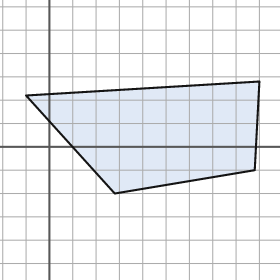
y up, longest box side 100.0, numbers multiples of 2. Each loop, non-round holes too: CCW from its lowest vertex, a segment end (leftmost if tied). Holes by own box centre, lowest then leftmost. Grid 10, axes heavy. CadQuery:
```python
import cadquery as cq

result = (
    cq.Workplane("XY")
    .moveTo(28.0, -20.0)
    .lineTo(88.0, -10.0)
    .lineTo(90.0, 28.0)
    .lineTo(-10.0, 22.0)
    .close()
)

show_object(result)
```